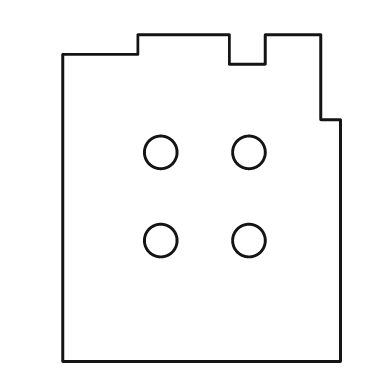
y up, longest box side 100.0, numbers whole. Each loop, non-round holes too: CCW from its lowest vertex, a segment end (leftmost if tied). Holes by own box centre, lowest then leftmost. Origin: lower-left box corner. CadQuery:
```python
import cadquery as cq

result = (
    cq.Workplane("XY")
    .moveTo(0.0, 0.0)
    .lineTo(85.0, 0.0)
    .lineTo(85.0, 74.0)
    .lineTo(79.0, 74.0)
    .lineTo(79.0, 100.0)
    .lineTo(62.0, 100.0)
    .lineTo(62.0, 91.0)
    .lineTo(51.0, 91.0)
    .lineTo(51.0, 100.0)
    .lineTo(23.0, 100.0)
    .lineTo(23.0, 94.0)
    .lineTo(0.0, 94.0)
    .close()
    .moveTo(30.0, 37.0)
    .circle(5.0)
    .moveTo(57.0, 37.0)
    .circle(5.0)
    .moveTo(30.0, 64.0)
    .circle(5.0)
    .moveTo(57.0, 64.0)
    .circle(5.0)
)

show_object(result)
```